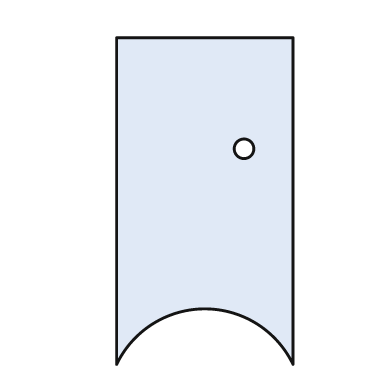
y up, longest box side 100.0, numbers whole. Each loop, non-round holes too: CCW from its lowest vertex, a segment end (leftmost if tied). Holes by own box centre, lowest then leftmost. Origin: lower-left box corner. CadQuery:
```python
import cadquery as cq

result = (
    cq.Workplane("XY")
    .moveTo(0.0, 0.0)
    .threePointArc((27.0, 17.0), (54.0, 0.0))
    .lineTo(54.0, 100.0)
    .lineTo(0.0, 100.0)
    .close()
    .moveTo(39.0, 66.0)
    .circle(3.0)
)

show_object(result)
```